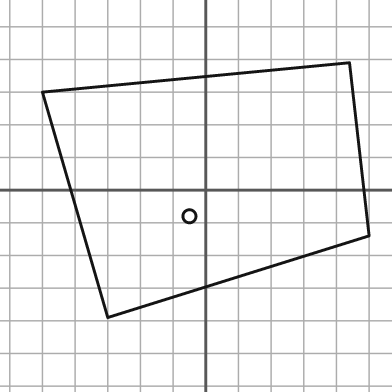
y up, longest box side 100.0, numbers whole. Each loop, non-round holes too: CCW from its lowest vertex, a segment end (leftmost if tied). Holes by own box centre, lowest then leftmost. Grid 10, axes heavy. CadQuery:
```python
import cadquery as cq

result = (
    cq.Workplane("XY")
    .moveTo(-30.0, -39.0)
    .lineTo(50.0, -14.0)
    .lineTo(44.0, 39.0)
    .lineTo(-50.0, 30.0)
    .close()
    .moveTo(-5.0, -8.0)
    .circle(2.0)
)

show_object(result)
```